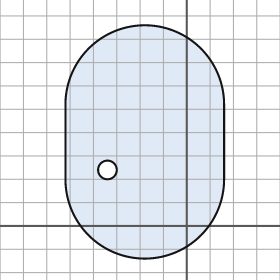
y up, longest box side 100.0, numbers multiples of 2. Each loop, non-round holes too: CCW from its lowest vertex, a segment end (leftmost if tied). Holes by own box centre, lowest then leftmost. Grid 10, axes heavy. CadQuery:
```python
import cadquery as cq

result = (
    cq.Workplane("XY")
    .moveTo(-52.0, 20.0)
    .threePointArc((-18.0, -14.0), (16.0, 20.0))
    .lineTo(16.0, 52.0)
    .threePointArc((-18.0, 86.0), (-52.0, 52.0))
    .close()
    .moveTo(-34.0, 24.0)
    .circle(4.0)
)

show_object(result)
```